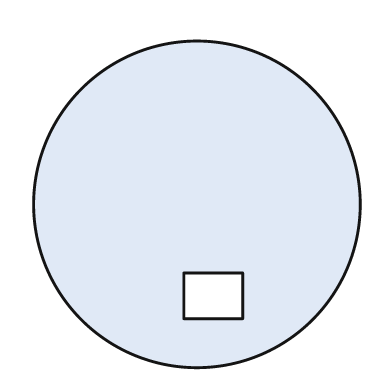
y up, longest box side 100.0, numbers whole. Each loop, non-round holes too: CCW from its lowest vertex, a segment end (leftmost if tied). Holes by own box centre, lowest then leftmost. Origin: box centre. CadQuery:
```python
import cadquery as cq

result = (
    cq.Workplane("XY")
    .moveTo(0.0, 0.0)
    .circle(50.0)
    .moveTo(-4.0, -35.0)
    .lineTo(14.0, -35.0)
    .lineTo(14.0, -21.0)
    .lineTo(-4.0, -21.0)
    .close()
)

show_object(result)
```